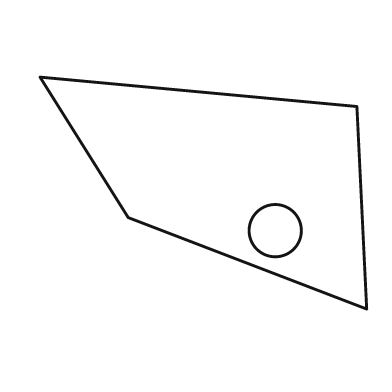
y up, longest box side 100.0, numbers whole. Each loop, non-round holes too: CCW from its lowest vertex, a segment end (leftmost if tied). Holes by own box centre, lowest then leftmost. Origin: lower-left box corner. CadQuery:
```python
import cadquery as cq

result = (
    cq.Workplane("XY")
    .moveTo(100.0, 0.0)
    .lineTo(97.0, 62.0)
    .lineTo(0.0, 71.0)
    .lineTo(27.0, 28.0)
    .close()
    .moveTo(72.0, 24.0)
    .circle(8.0)
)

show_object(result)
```